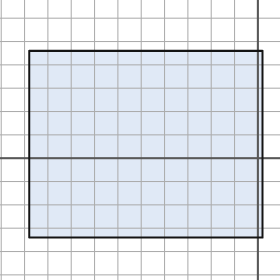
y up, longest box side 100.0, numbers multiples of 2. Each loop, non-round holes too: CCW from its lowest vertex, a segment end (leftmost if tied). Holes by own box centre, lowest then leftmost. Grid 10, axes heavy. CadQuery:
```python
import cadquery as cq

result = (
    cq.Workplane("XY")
    .moveTo(-98.0, -34.0)
    .lineTo(2.0, -34.0)
    .lineTo(2.0, 46.0)
    .lineTo(-98.0, 46.0)
    .close()
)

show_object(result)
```